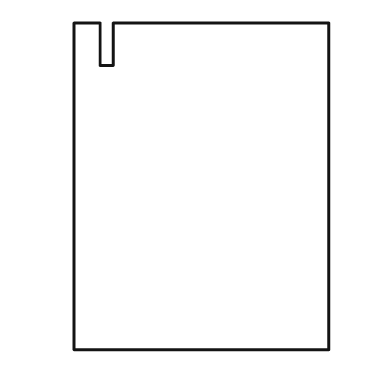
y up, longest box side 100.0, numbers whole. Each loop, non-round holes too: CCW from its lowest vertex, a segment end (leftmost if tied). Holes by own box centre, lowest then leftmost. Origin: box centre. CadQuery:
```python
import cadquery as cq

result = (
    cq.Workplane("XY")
    .moveTo(-39.0, -50.0)
    .lineTo(39.0, -50.0)
    .lineTo(39.0, 50.0)
    .lineTo(-27.0, 50.0)
    .lineTo(-27.0, 37.0)
    .lineTo(-31.0, 37.0)
    .lineTo(-31.0, 50.0)
    .lineTo(-39.0, 50.0)
    .close()
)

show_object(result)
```